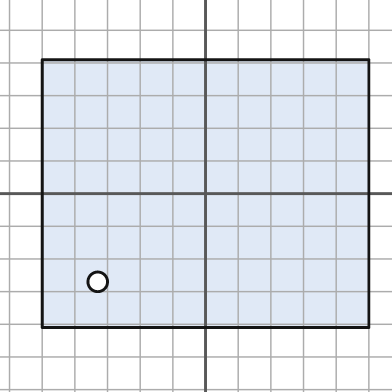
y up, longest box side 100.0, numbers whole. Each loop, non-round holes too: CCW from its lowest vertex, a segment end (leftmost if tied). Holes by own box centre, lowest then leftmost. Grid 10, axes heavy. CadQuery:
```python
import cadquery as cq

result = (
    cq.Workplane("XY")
    .moveTo(-50.0, -41.0)
    .lineTo(50.0, -41.0)
    .lineTo(50.0, 41.0)
    .lineTo(-50.0, 41.0)
    .close()
    .moveTo(-33.0, -27.0)
    .circle(3.0)
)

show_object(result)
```